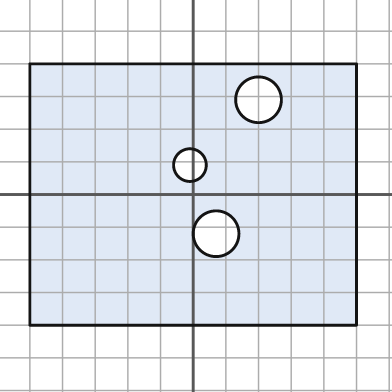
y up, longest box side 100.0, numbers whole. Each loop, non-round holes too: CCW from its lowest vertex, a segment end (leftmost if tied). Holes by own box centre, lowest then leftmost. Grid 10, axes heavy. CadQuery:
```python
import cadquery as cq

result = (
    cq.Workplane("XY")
    .moveTo(-50.0, -40.0)
    .lineTo(50.0, -40.0)
    .lineTo(50.0, 40.0)
    .lineTo(-50.0, 40.0)
    .close()
    .moveTo(7.0, -12.0)
    .circle(7.0)
    .moveTo(-1.0, 9.0)
    .circle(5.0)
    .moveTo(20.0, 29.0)
    .circle(7.0)
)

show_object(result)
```